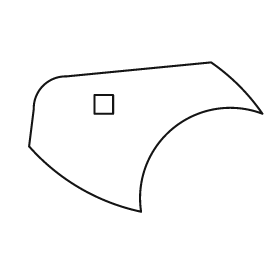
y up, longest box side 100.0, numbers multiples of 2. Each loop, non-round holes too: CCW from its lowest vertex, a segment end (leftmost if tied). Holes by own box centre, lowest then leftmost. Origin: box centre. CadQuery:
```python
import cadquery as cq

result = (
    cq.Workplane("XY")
    .moveTo(-2.0, -32.0)
    .threePointArc((12.0, 4.0), (50.0, 10.0))
    .threePointArc((40.0, 22.0), (28.0, 32.0))
    .lineTo(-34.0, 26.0)
    .threePointArc((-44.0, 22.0), (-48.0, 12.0))
    .lineTo(-50.0, -4.0)
    .threePointArc((-28.0, -22.0), (-2.0, -32.0))
    .close()
    .moveTo(-22.0, 10.0)
    .lineTo(-14.0, 10.0)
    .lineTo(-14.0, 18.0)
    .lineTo(-22.0, 18.0)
    .close()
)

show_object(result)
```